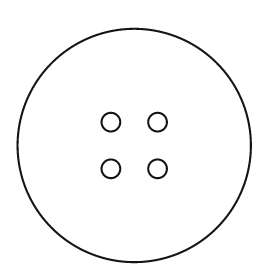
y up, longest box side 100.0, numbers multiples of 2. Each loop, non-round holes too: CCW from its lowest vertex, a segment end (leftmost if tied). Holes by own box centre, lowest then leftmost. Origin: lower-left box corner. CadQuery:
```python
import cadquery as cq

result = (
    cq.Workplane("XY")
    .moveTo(50.0, 50.0)
    .circle(50.0)
    .moveTo(40.0, 40.0)
    .circle(4.0)
    .moveTo(60.0, 40.0)
    .circle(4.0)
    .moveTo(40.0, 60.0)
    .circle(4.0)
    .moveTo(60.0, 60.0)
    .circle(4.0)
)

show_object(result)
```